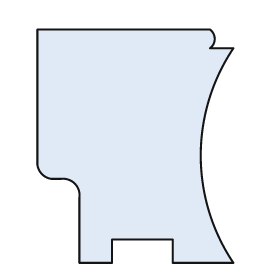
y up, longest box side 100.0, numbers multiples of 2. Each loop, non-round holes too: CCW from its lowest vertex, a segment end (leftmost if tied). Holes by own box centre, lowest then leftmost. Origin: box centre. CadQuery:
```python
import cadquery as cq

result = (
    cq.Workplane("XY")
    .moveTo(-24.0, -50.0)
    .lineTo(-10.0, -50.0)
    .lineTo(-10.0, -40.0)
    .lineTo(16.0, -40.0)
    .lineTo(16.0, -50.0)
    .lineTo(42.0, -50.0)
    .threePointArc((28.0, -4.0), (42.0, 42.0))
    .lineTo(32.0, 42.0)
    .threePointArc((34.0, 46.0), (32.0, 50.0))
    .lineTo(-42.0, 50.0)
    .lineTo(-42.0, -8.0)
    .threePointArc((-40.0, -12.0), (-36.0, -14.0))
    .lineTo(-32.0, -14.0)
    .threePointArc((-26.0, -16.0), (-24.0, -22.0))
    .close()
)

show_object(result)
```